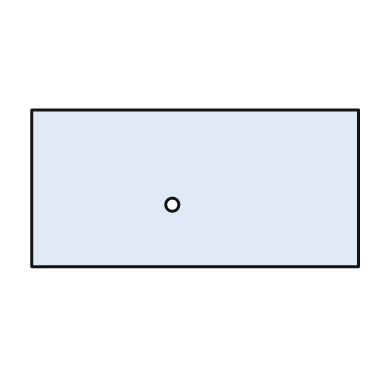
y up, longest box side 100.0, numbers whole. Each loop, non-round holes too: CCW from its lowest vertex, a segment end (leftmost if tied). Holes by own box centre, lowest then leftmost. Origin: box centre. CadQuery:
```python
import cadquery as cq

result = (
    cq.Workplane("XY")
    .moveTo(-50.0, -24.0)
    .lineTo(50.0, -24.0)
    .lineTo(50.0, 24.0)
    .lineTo(-50.0, 24.0)
    .close()
    .moveTo(-7.0, -5.0)
    .circle(2.0)
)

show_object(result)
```